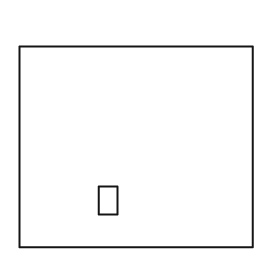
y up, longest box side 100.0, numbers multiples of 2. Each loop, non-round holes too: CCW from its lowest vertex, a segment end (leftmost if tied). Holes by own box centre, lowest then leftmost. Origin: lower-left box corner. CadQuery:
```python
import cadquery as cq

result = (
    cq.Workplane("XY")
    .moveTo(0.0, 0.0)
    .lineTo(100.0, 0.0)
    .lineTo(100.0, 86.0)
    .lineTo(0.0, 86.0)
    .close()
    .moveTo(34.0, 14.0)
    .lineTo(42.0, 14.0)
    .lineTo(42.0, 26.0)
    .lineTo(34.0, 26.0)
    .close()
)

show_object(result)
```